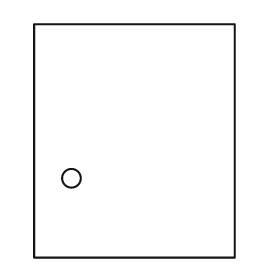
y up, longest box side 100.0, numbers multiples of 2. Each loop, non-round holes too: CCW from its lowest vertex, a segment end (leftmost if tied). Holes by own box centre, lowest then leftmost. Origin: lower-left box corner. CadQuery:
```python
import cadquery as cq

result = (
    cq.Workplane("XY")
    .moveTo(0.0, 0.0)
    .lineTo(86.0, 0.0)
    .lineTo(86.0, 100.0)
    .lineTo(0.0, 100.0)
    .close()
    .moveTo(16.0, 34.0)
    .circle(4.0)
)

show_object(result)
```